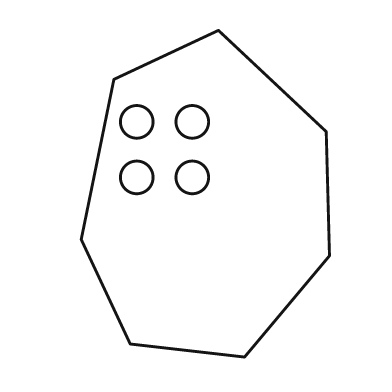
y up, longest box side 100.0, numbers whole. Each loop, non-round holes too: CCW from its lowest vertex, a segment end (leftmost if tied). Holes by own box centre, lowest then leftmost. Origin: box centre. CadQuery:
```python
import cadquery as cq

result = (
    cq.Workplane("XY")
    .moveTo(12.0, -50.0)
    .lineTo(38.0, -19.0)
    .lineTo(37.0, 19.0)
    .lineTo(4.0, 50.0)
    .lineTo(-28.0, 35.0)
    .lineTo(-38.0, -14.0)
    .lineTo(-23.0, -46.0)
    .close()
    .moveTo(-21.0, 5.0)
    .circle(5.0)
    .moveTo(-4.0, 5.0)
    .circle(5.0)
    .moveTo(-21.0, 22.0)
    .circle(5.0)
    .moveTo(-4.0, 22.0)
    .circle(5.0)
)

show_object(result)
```